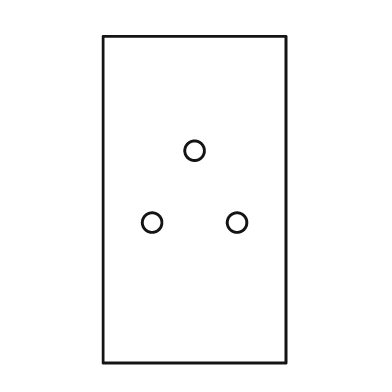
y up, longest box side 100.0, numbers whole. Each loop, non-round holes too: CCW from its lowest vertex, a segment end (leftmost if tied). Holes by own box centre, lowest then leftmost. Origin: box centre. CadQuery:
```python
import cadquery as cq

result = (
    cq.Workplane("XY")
    .moveTo(-28.0, -50.0)
    .lineTo(28.0, -50.0)
    .lineTo(28.0, 50.0)
    .lineTo(-28.0, 50.0)
    .close()
    .moveTo(-13.0, -7.0)
    .circle(3.0)
    .moveTo(13.0, -7.0)
    .circle(3.0)
    .moveTo(0.0, 15.0)
    .circle(3.0)
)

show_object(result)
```